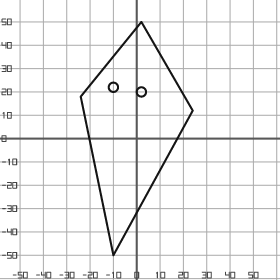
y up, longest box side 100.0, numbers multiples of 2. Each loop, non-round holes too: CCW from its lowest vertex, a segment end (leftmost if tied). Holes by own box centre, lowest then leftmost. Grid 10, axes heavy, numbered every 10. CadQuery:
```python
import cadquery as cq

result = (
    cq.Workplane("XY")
    .moveTo(-10.0, -50.0)
    .lineTo(24.0, 12.0)
    .lineTo(2.0, 50.0)
    .lineTo(-24.0, 18.0)
    .close()
    .moveTo(2.0, 20.0)
    .circle(2.0)
    .moveTo(-10.0, 22.0)
    .circle(2.0)
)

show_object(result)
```